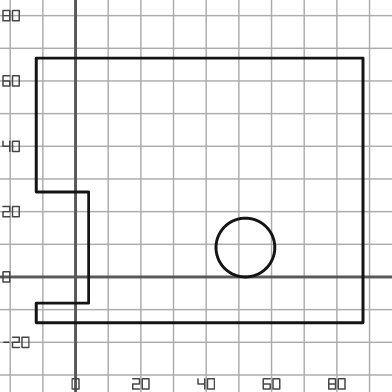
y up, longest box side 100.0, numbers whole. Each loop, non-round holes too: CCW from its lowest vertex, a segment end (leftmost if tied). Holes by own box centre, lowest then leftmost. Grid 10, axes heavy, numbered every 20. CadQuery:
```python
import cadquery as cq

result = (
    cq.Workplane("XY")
    .moveTo(-12.0, -14.0)
    .lineTo(88.0, -14.0)
    .lineTo(88.0, 67.0)
    .lineTo(-12.0, 67.0)
    .lineTo(-12.0, 26.0)
    .lineTo(4.0, 26.0)
    .lineTo(4.0, -8.0)
    .lineTo(-12.0, -8.0)
    .close()
    .moveTo(52.0, 9.0)
    .circle(9.0)
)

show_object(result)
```